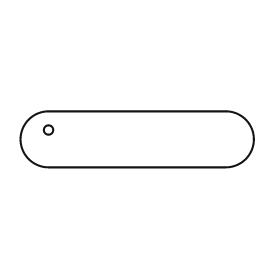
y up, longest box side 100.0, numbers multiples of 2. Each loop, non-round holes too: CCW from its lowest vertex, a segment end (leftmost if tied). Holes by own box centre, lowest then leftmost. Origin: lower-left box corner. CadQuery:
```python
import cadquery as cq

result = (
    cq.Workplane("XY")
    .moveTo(12.0, 0.0)
    .lineTo(88.0, 0.0)
    .threePointArc((100.0, 12.0), (88.0, 24.0))
    .lineTo(12.0, 24.0)
    .threePointArc((0.0, 12.0), (12.0, 0.0))
    .close()
    .moveTo(12.0, 16.0)
    .circle(2.0)
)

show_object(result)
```